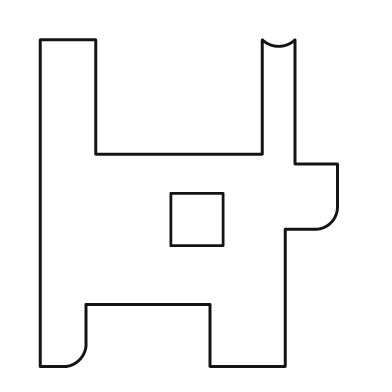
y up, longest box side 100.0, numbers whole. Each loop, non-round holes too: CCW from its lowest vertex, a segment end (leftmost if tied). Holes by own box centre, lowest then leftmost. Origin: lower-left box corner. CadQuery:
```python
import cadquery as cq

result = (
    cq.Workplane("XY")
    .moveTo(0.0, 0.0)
    .lineTo(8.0, 0.0)
    .threePointArc((12.0, 2.0), (14.0, 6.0))
    .lineTo(14.0, 19.0)
    .lineTo(52.0, 19.0)
    .lineTo(52.0, 0.0)
    .lineTo(75.0, 0.0)
    .lineTo(75.0, 42.0)
    .lineTo(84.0, 42.0)
    .threePointArc((89.0, 44.0), (91.0, 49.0))
    .lineTo(91.0, 62.0)
    .lineTo(78.0, 62.0)
    .lineTo(78.0, 100.0)
    .threePointArc((73.0, 98.0), (68.0, 100.0))
    .lineTo(68.0, 65.0)
    .lineTo(17.0, 65.0)
    .lineTo(17.0, 100.0)
    .lineTo(0.0, 100.0)
    .close()
    .moveTo(40.0, 37.0)
    .lineTo(56.0, 37.0)
    .lineTo(56.0, 53.0)
    .lineTo(40.0, 53.0)
    .close()
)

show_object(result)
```